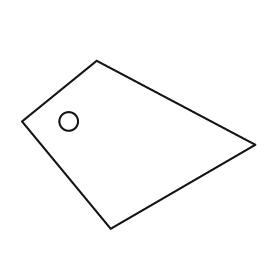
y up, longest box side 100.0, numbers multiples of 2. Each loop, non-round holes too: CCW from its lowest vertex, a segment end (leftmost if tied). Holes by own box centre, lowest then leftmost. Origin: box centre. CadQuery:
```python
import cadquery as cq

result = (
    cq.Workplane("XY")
    .moveTo(-12.0, -36.0)
    .lineTo(50.0, 0.0)
    .lineTo(-18.0, 36.0)
    .lineTo(-50.0, 10.0)
    .close()
    .moveTo(-30.0, 10.0)
    .circle(4.0)
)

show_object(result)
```